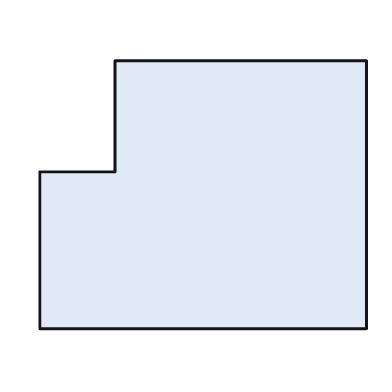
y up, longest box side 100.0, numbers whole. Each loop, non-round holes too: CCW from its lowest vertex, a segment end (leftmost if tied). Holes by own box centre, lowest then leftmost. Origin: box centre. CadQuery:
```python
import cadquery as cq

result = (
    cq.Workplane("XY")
    .moveTo(-50.0, -41.0)
    .lineTo(50.0, -41.0)
    .lineTo(50.0, 41.0)
    .lineTo(-27.0, 41.0)
    .lineTo(-27.0, 7.0)
    .lineTo(-50.0, 7.0)
    .close()
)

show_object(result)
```